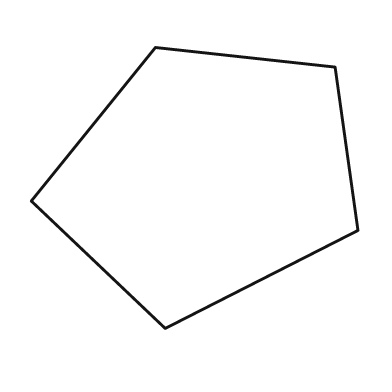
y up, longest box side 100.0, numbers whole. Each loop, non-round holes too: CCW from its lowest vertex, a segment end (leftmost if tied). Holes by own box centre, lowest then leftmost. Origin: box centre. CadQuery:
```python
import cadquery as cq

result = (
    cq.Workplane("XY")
    .moveTo(-9.0, -43.0)
    .lineTo(50.0, -13.0)
    .lineTo(43.0, 37.0)
    .lineTo(-12.0, 43.0)
    .lineTo(-50.0, -4.0)
    .close()
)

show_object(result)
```